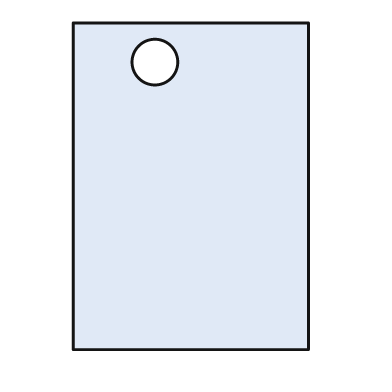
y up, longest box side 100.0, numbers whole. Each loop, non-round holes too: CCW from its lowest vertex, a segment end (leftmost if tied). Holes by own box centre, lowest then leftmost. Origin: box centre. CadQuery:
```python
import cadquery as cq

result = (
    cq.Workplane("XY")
    .moveTo(-36.0, -50.0)
    .lineTo(36.0, -50.0)
    .lineTo(36.0, 50.0)
    .lineTo(-36.0, 50.0)
    .close()
    .moveTo(-11.0, 38.0)
    .circle(7.0)
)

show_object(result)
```